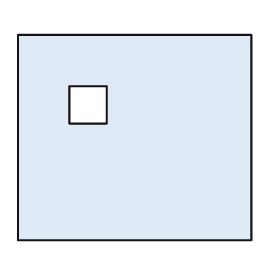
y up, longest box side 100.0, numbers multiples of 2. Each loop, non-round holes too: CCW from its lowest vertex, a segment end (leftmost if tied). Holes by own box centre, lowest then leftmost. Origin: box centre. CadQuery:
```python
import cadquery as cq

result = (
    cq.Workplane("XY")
    .moveTo(-50.0, -44.0)
    .lineTo(50.0, -44.0)
    .lineTo(50.0, 44.0)
    .lineTo(-50.0, 44.0)
    .close()
    .moveTo(-28.0, 6.0)
    .lineTo(-12.0, 6.0)
    .lineTo(-12.0, 22.0)
    .lineTo(-28.0, 22.0)
    .close()
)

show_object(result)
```